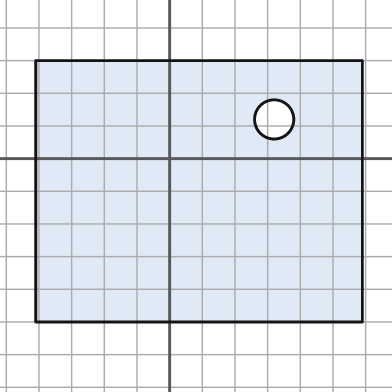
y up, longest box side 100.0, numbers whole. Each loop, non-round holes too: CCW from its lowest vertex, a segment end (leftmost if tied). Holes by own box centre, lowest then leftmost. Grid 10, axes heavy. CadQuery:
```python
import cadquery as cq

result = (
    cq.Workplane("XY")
    .moveTo(-41.0, -50.0)
    .lineTo(59.0, -50.0)
    .lineTo(59.0, 30.0)
    .lineTo(-41.0, 30.0)
    .close()
    .moveTo(32.0, 12.0)
    .circle(6.0)
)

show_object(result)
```